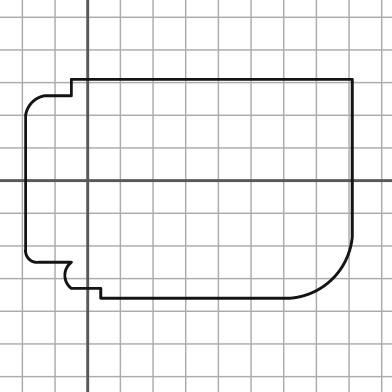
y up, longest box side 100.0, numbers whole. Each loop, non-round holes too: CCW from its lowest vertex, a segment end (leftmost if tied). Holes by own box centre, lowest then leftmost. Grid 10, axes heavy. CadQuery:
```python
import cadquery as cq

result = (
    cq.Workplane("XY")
    .moveTo(4.0, -36.0)
    .lineTo(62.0, -36.0)
    .threePointArc((75.0, -30.0), (81.0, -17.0))
    .lineTo(81.0, 31.0)
    .lineTo(-5.0, 31.0)
    .lineTo(-5.0, 26.0)
    .lineTo(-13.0, 26.0)
    .threePointArc((-17.0, 24.0), (-19.0, 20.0))
    .lineTo(-19.0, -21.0)
    .threePointArc((-18.0, -24.0), (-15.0, -25.0))
    .lineTo(-5.0, -25.0)
    .threePointArc((-7.0, -29.0), (-5.0, -33.0))
    .lineTo(4.0, -33.0)
    .close()
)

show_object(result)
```